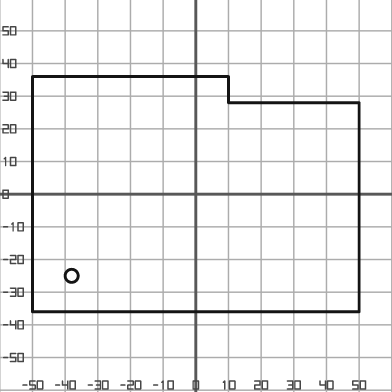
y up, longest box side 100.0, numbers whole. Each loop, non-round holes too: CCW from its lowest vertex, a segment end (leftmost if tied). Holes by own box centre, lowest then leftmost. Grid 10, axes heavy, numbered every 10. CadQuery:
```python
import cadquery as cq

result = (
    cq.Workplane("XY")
    .moveTo(-50.0, -36.0)
    .lineTo(50.0, -36.0)
    .lineTo(50.0, 28.0)
    .lineTo(10.0, 28.0)
    .lineTo(10.0, 36.0)
    .lineTo(-50.0, 36.0)
    .close()
    .moveTo(-38.0, -25.0)
    .circle(2.0)
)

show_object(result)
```